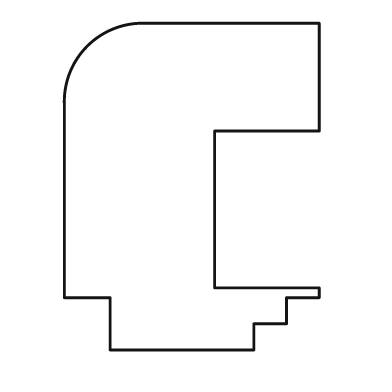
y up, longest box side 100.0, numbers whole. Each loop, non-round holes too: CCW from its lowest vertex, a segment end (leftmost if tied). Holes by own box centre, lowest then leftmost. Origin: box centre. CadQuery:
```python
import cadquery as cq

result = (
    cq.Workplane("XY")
    .moveTo(-25.0, -50.0)
    .lineTo(19.0, -50.0)
    .lineTo(19.0, -42.0)
    .lineTo(29.0, -42.0)
    .lineTo(29.0, -34.0)
    .lineTo(39.0, -34.0)
    .lineTo(39.0, -31.0)
    .lineTo(7.0, -31.0)
    .lineTo(7.0, 17.0)
    .lineTo(39.0, 17.0)
    .lineTo(39.0, 50.0)
    .lineTo(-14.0, 50.0)
    .threePointArc((-32.0, 43.0), (-39.0, 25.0))
    .lineTo(-39.0, -34.0)
    .lineTo(-25.0, -34.0)
    .close()
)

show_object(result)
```